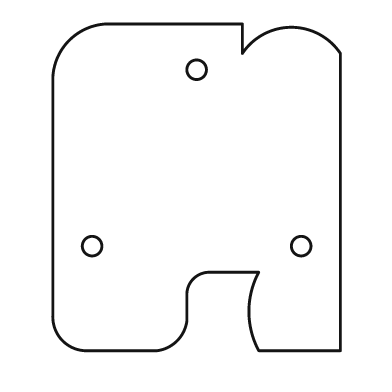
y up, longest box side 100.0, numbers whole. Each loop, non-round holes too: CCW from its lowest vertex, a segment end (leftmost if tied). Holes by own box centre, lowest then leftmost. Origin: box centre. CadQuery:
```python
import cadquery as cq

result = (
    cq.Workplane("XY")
    .moveTo(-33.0, -50.0)
    .lineTo(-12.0, -50.0)
    .threePointArc((-6.0, -47.0), (-3.0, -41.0))
    .lineTo(-3.0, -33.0)
    .threePointArc((-1.0, -28.0), (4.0, -26.0))
    .lineTo(19.0, -26.0)
    .threePointArc((16.0, -38.0), (19.0, -50.0))
    .lineTo(44.0, -50.0)
    .lineTo(44.0, 41.0)
    .threePointArc((29.0, 49.0), (14.0, 41.0))
    .lineTo(14.0, 50.0)
    .lineTo(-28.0, 50.0)
    .threePointArc((-39.0, 45.0), (-44.0, 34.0))
    .lineTo(-44.0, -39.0)
    .threePointArc((-41.0, -47.0), (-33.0, -50.0))
    .close()
    .moveTo(-32.0, -18.0)
    .circle(3.0)
    .moveTo(32.0, -18.0)
    .circle(3.0)
    .moveTo(0.0, 36.0)
    .circle(3.0)
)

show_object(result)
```